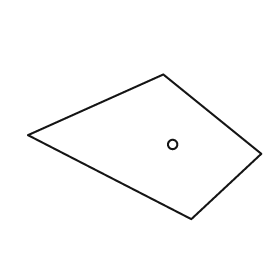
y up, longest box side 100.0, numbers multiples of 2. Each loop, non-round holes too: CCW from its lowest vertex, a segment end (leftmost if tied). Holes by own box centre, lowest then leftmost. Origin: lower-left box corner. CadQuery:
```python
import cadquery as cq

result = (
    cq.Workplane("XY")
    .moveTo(70.0, 0.0)
    .lineTo(100.0, 28.0)
    .lineTo(58.0, 62.0)
    .lineTo(0.0, 36.0)
    .close()
    .moveTo(62.0, 32.0)
    .circle(2.0)
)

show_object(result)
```